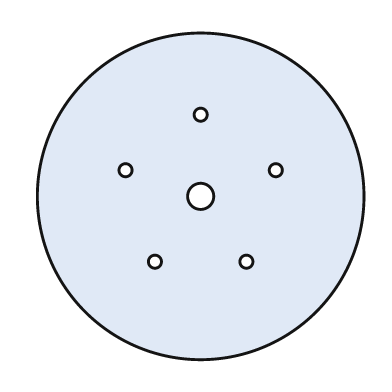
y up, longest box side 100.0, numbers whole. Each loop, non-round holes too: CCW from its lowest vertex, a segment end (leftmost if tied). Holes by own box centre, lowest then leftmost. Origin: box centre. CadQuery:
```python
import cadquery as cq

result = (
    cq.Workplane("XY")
    .moveTo(0.0, 0.0)
    .circle(50.0)
    .moveTo(-14.0, -20.0)
    .circle(2.0)
    .moveTo(14.0, -20.0)
    .circle(2.0)
    .moveTo(0.0, 0.0)
    .circle(4.0)
    .moveTo(-23.0, 8.0)
    .circle(2.0)
    .moveTo(23.0, 8.0)
    .circle(2.0)
    .moveTo(0.0, 25.0)
    .circle(2.0)
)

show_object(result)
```